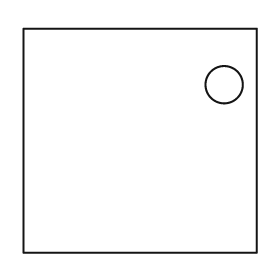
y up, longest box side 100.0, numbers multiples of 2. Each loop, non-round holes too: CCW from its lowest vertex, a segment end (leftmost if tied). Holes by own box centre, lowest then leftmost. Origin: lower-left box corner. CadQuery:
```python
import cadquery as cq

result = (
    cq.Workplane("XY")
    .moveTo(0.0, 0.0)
    .lineTo(100.0, 0.0)
    .lineTo(100.0, 96.0)
    .lineTo(0.0, 96.0)
    .close()
    .moveTo(86.0, 72.0)
    .circle(8.0)
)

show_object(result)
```